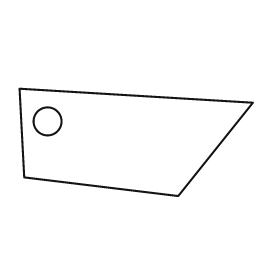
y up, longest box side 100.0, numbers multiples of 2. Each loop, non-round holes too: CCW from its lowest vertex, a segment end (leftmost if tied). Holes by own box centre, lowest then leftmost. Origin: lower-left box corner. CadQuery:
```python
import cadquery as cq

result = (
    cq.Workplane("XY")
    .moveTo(68.0, 0.0)
    .lineTo(100.0, 40.0)
    .lineTo(0.0, 46.0)
    .lineTo(2.0, 8.0)
    .close()
    .moveTo(12.0, 32.0)
    .circle(6.0)
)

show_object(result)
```